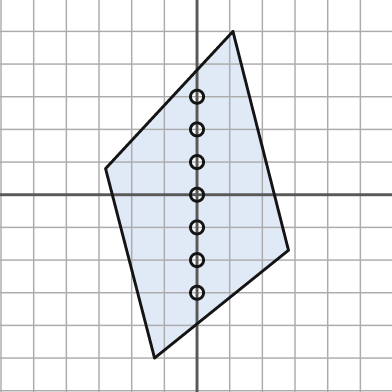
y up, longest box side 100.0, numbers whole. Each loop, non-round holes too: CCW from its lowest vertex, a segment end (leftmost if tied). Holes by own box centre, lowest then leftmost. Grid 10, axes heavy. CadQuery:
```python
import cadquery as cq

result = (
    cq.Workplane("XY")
    .moveTo(-13.0, -50.0)
    .lineTo(28.0, -17.0)
    .lineTo(11.0, 50.0)
    .lineTo(-28.0, 8.0)
    .close()
    .moveTo(0.0, -30.0)
    .circle(2.0)
    .moveTo(0.0, -20.0)
    .circle(2.0)
    .moveTo(0.0, -10.0)
    .circle(2.0)
    .moveTo(0.0, 0.0)
    .circle(2.0)
    .moveTo(0.0, 10.0)
    .circle(2.0)
    .moveTo(0.0, 20.0)
    .circle(2.0)
    .moveTo(0.0, 30.0)
    .circle(2.0)
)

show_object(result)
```